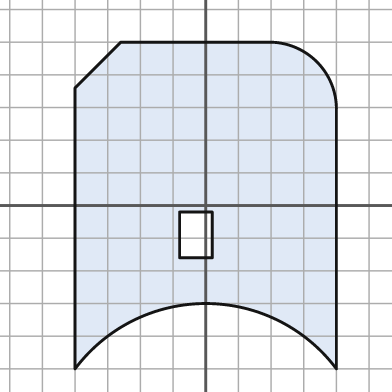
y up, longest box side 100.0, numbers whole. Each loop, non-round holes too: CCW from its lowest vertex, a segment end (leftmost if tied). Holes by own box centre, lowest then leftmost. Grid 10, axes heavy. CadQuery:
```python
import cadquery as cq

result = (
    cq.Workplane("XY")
    .moveTo(-40.0, -50.0)
    .threePointArc((0.0, -30.0), (40.0, -50.0))
    .lineTo(40.0, 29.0)
    .threePointArc((34.0, 44.0), (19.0, 50.0))
    .lineTo(-26.0, 50.0)
    .lineTo(-40.0, 36.0)
    .close()
    .moveTo(-8.0, -16.0)
    .lineTo(2.0, -16.0)
    .lineTo(2.0, -2.0)
    .lineTo(-8.0, -2.0)
    .close()
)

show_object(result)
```